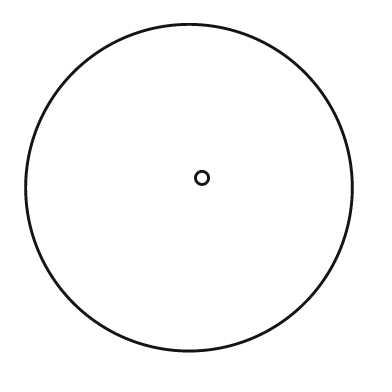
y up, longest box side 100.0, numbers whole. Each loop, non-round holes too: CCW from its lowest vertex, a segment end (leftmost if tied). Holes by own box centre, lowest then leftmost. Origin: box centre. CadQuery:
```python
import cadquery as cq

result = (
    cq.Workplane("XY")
    .moveTo(0.0, 0.0)
    .circle(50.0)
    .moveTo(4.0, 3.0)
    .circle(2.0)
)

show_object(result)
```